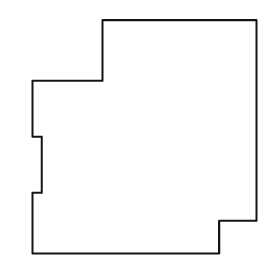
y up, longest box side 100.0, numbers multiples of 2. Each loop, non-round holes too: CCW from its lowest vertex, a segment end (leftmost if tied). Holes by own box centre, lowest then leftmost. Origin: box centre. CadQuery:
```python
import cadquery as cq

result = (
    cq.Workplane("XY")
    .moveTo(-48.0, -50.0)
    .lineTo(32.0, -50.0)
    .lineTo(32.0, -36.0)
    .lineTo(48.0, -36.0)
    .lineTo(48.0, 50.0)
    .lineTo(-18.0, 50.0)
    .lineTo(-18.0, 24.0)
    .lineTo(-48.0, 24.0)
    .lineTo(-48.0, 0.0)
    .lineTo(-44.0, 0.0)
    .lineTo(-44.0, -24.0)
    .lineTo(-48.0, -24.0)
    .close()
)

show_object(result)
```